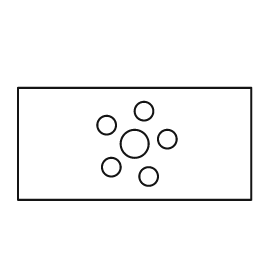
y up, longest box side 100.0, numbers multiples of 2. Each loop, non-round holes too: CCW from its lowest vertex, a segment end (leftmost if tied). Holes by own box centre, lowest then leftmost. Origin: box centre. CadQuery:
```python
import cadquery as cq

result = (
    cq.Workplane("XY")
    .moveTo(-50.0, -24.0)
    .lineTo(50.0, -24.0)
    .lineTo(50.0, 24.0)
    .lineTo(-50.0, 24.0)
    .close()
    .moveTo(6.0, -14.0)
    .circle(4.0)
    .moveTo(-10.0, -10.0)
    .circle(4.0)
    .moveTo(0.0, 0.0)
    .circle(6.0)
    .moveTo(14.0, 2.0)
    .circle(4.0)
    .moveTo(-12.0, 8.0)
    .circle(4.0)
    .moveTo(4.0, 14.0)
    .circle(4.0)
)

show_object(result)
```